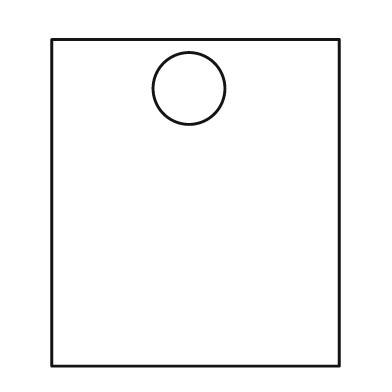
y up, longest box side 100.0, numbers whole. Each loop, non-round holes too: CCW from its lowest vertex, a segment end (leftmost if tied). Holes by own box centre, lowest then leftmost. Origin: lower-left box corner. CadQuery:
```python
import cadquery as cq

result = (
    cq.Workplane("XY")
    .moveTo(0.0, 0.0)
    .lineTo(88.0, 0.0)
    .lineTo(88.0, 100.0)
    .lineTo(0.0, 100.0)
    .close()
    .moveTo(42.0, 85.0)
    .circle(11.0)
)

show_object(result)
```